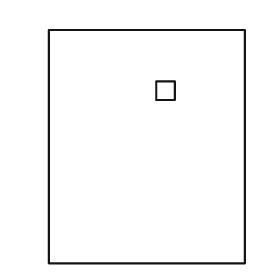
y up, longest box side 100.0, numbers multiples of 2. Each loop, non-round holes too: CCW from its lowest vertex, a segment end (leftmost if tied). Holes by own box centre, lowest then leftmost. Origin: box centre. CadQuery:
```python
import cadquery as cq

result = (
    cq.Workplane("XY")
    .moveTo(-42.0, -50.0)
    .lineTo(42.0, -50.0)
    .lineTo(42.0, 50.0)
    .lineTo(-42.0, 50.0)
    .close()
    .moveTo(4.0, 20.0)
    .lineTo(12.0, 20.0)
    .lineTo(12.0, 28.0)
    .lineTo(4.0, 28.0)
    .close()
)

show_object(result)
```